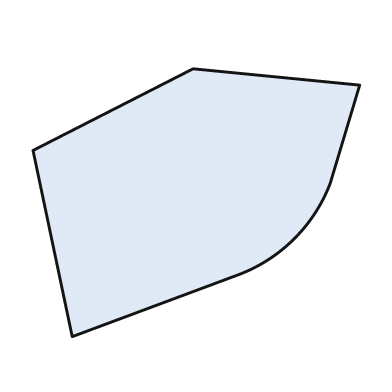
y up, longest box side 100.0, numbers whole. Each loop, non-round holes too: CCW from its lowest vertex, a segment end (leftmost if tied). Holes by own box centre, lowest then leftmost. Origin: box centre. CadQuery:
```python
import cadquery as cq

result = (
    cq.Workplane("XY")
    .moveTo(-38.0, -41.0)
    .lineTo(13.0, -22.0)
    .threePointArc((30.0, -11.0), (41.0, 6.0))
    .lineTo(50.0, 36.0)
    .lineTo(-1.0, 41.0)
    .lineTo(-50.0, 16.0)
    .close()
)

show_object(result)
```